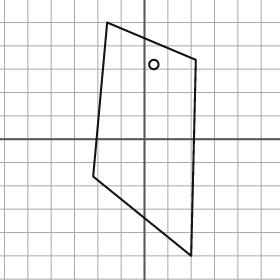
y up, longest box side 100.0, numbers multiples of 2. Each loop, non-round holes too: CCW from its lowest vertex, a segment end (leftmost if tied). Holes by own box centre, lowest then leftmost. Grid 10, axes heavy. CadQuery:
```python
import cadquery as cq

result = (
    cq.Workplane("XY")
    .moveTo(20.0, -50.0)
    .lineTo(22.0, 34.0)
    .lineTo(-16.0, 50.0)
    .lineTo(-22.0, -16.0)
    .close()
    .moveTo(4.0, 32.0)
    .circle(2.0)
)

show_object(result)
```